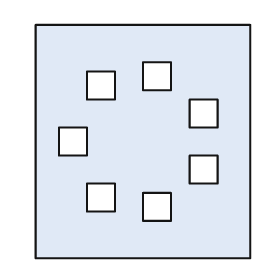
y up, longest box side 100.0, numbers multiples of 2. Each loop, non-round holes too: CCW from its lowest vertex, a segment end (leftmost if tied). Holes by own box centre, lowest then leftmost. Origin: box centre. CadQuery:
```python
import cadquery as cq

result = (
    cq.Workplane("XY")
    .moveTo(-46.0, -50.0)
    .lineTo(46.0, -50.0)
    .lineTo(46.0, 50.0)
    .lineTo(-46.0, 50.0)
    .close()
    .moveTo(0.0, -34.0)
    .lineTo(12.0, -34.0)
    .lineTo(12.0, -22.0)
    .lineTo(0.0, -22.0)
    .close()
    .moveTo(-24.0, -30.0)
    .lineTo(-12.0, -30.0)
    .lineTo(-12.0, -18.0)
    .lineTo(-24.0, -18.0)
    .close()
    .moveTo(20.0, -18.0)
    .lineTo(32.0, -18.0)
    .lineTo(32.0, -6.0)
    .lineTo(20.0, -6.0)
    .close()
    .moveTo(-36.0, -6.0)
    .lineTo(-24.0, -6.0)
    .lineTo(-24.0, 6.0)
    .lineTo(-36.0, 6.0)
    .close()
    .moveTo(20.0, 6.0)
    .lineTo(32.0, 6.0)
    .lineTo(32.0, 18.0)
    .lineTo(20.0, 18.0)
    .close()
    .moveTo(-24.0, 18.0)
    .lineTo(-12.0, 18.0)
    .lineTo(-12.0, 30.0)
    .lineTo(-24.0, 30.0)
    .close()
    .moveTo(0.0, 22.0)
    .lineTo(12.0, 22.0)
    .lineTo(12.0, 34.0)
    .lineTo(0.0, 34.0)
    .close()
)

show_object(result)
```